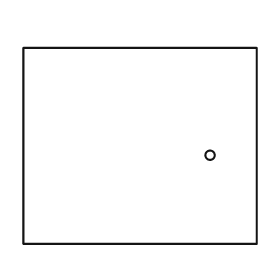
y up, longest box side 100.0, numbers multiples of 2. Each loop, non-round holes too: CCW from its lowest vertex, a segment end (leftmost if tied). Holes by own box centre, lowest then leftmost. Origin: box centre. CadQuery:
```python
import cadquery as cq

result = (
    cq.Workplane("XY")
    .moveTo(-50.0, -42.0)
    .lineTo(50.0, -42.0)
    .lineTo(50.0, 42.0)
    .lineTo(-50.0, 42.0)
    .close()
    .moveTo(30.0, -4.0)
    .circle(2.0)
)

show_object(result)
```